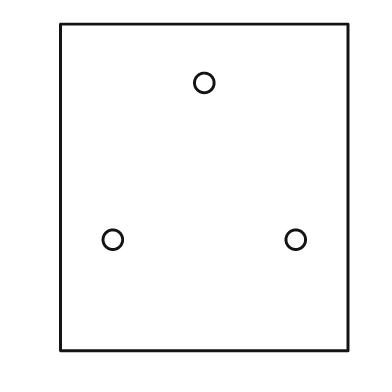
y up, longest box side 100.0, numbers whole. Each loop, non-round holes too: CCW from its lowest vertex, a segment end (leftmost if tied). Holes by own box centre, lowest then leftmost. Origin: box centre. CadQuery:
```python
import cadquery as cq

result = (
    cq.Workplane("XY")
    .moveTo(-44.0, -50.0)
    .lineTo(44.0, -50.0)
    .lineTo(44.0, 50.0)
    .lineTo(-44.0, 50.0)
    .close()
    .moveTo(-28.0, -16.0)
    .circle(3.0)
    .moveTo(28.0, -16.0)
    .circle(3.0)
    .moveTo(0.0, 32.0)
    .circle(3.0)
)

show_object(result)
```